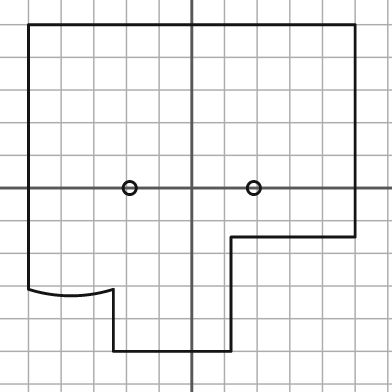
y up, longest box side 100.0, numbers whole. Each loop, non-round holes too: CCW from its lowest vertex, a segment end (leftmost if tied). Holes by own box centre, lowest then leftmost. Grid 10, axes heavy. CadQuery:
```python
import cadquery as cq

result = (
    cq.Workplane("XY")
    .moveTo(-24.0, -50.0)
    .lineTo(12.0, -50.0)
    .lineTo(12.0, -15.0)
    .lineTo(50.0, -15.0)
    .lineTo(50.0, 50.0)
    .lineTo(-50.0, 50.0)
    .lineTo(-50.0, -31.0)
    .threePointArc((-37.0, -33.0), (-24.0, -31.0))
    .close()
    .moveTo(-19.0, 0.0)
    .circle(2.0)
    .moveTo(19.0, 0.0)
    .circle(2.0)
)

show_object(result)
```